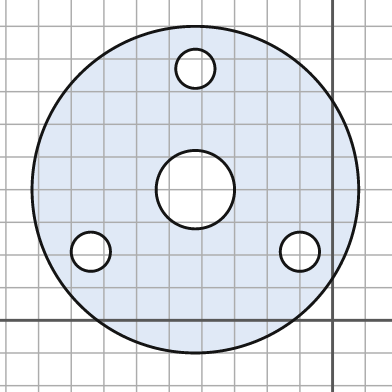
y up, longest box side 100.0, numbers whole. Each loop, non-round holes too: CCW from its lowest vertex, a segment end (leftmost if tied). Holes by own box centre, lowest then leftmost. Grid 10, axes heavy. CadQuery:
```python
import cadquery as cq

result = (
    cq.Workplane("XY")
    .moveTo(-42.0, 40.0)
    .circle(50.0)
    .moveTo(-74.0, 21.0)
    .circle(6.0)
    .moveTo(-10.0, 21.0)
    .circle(6.0)
    .moveTo(-42.0, 40.0)
    .circle(12.0)
    .moveTo(-42.0, 77.0)
    .circle(6.0)
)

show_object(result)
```